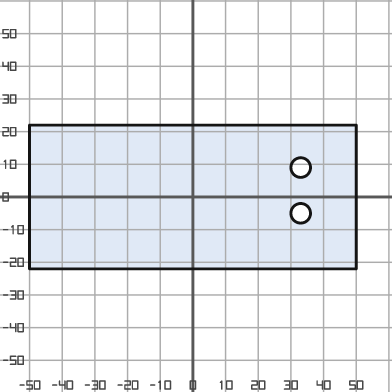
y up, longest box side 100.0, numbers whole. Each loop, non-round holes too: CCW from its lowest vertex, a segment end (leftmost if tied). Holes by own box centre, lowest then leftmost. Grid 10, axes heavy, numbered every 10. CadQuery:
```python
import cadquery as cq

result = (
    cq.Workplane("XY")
    .moveTo(-50.0, -22.0)
    .lineTo(50.0, -22.0)
    .lineTo(50.0, 22.0)
    .lineTo(-50.0, 22.0)
    .close()
    .moveTo(33.0, -5.0)
    .circle(3.0)
    .moveTo(33.0, 9.0)
    .circle(3.0)
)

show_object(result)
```